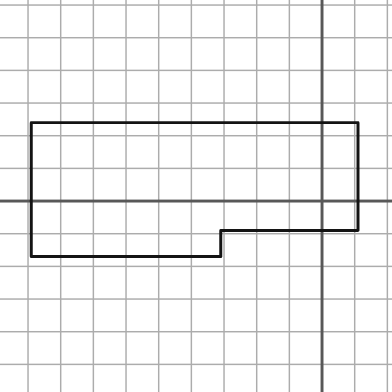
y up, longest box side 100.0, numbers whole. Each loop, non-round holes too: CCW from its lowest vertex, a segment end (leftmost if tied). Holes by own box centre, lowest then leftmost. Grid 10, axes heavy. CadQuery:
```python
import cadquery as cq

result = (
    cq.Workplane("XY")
    .moveTo(-89.0, -17.0)
    .lineTo(-31.0, -17.0)
    .lineTo(-31.0, -9.0)
    .lineTo(11.0, -9.0)
    .lineTo(11.0, 24.0)
    .lineTo(-89.0, 24.0)
    .close()
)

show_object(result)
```